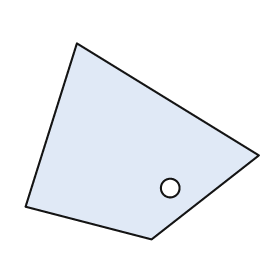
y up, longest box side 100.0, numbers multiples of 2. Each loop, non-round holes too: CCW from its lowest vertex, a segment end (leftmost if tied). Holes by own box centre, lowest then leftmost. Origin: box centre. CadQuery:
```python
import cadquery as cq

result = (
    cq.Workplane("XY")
    .moveTo(4.0, -42.0)
    .lineTo(50.0, -6.0)
    .lineTo(-28.0, 42.0)
    .lineTo(-50.0, -28.0)
    .close()
    .moveTo(12.0, -20.0)
    .circle(4.0)
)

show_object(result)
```